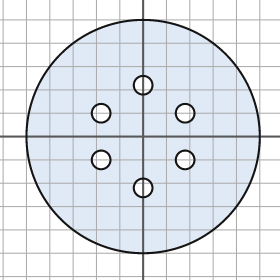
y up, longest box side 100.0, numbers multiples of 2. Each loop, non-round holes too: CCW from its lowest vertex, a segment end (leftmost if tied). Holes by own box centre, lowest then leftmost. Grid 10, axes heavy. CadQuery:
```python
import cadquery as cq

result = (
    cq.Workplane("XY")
    .moveTo(0.0, 0.0)
    .circle(50.0)
    .moveTo(0.0, -22.0)
    .circle(4.0)
    .moveTo(-18.0, -10.0)
    .circle(4.0)
    .moveTo(18.0, -10.0)
    .circle(4.0)
    .moveTo(-18.0, 10.0)
    .circle(4.0)
    .moveTo(18.0, 10.0)
    .circle(4.0)
    .moveTo(0.0, 22.0)
    .circle(4.0)
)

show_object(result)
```